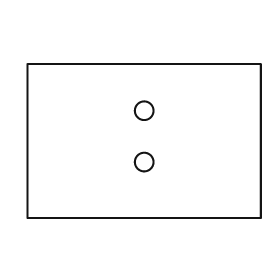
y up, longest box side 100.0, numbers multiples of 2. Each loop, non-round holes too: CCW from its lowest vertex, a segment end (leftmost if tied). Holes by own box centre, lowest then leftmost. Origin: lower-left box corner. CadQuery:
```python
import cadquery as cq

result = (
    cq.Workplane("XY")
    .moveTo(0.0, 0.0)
    .lineTo(100.0, 0.0)
    .lineTo(100.0, 66.0)
    .lineTo(0.0, 66.0)
    .close()
    .moveTo(50.0, 24.0)
    .circle(4.0)
    .moveTo(50.0, 46.0)
    .circle(4.0)
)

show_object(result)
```